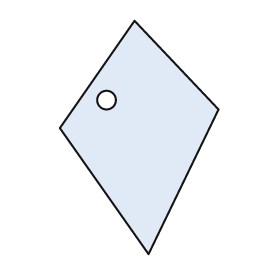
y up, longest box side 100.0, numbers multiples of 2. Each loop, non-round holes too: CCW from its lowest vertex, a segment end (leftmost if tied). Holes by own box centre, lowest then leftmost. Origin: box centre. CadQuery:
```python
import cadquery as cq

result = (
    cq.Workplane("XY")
    .moveTo(4.0, -50.0)
    .lineTo(34.0, 12.0)
    .lineTo(-2.0, 50.0)
    .lineTo(-34.0, 4.0)
    .close()
    .moveTo(-14.0, 16.0)
    .circle(4.0)
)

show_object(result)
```